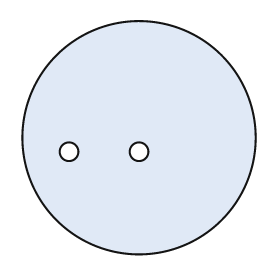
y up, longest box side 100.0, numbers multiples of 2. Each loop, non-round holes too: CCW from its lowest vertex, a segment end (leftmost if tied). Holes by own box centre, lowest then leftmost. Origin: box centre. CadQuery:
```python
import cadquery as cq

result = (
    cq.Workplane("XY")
    .moveTo(0.0, 0.0)
    .circle(50.0)
    .moveTo(-30.0, -6.0)
    .circle(4.0)
    .moveTo(0.0, -6.0)
    .circle(4.0)
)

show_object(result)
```